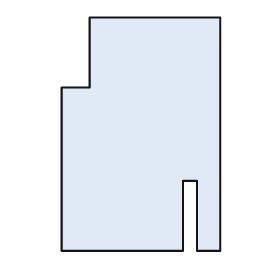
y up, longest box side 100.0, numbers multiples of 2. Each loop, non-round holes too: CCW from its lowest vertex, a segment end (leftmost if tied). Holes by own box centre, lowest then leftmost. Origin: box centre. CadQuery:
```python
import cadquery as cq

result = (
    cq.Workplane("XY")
    .moveTo(-34.0, -50.0)
    .lineTo(18.0, -50.0)
    .lineTo(18.0, -20.0)
    .lineTo(24.0, -20.0)
    .lineTo(24.0, -50.0)
    .lineTo(34.0, -50.0)
    .lineTo(34.0, 50.0)
    .lineTo(-22.0, 50.0)
    .lineTo(-22.0, 20.0)
    .lineTo(-34.0, 20.0)
    .close()
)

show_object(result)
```